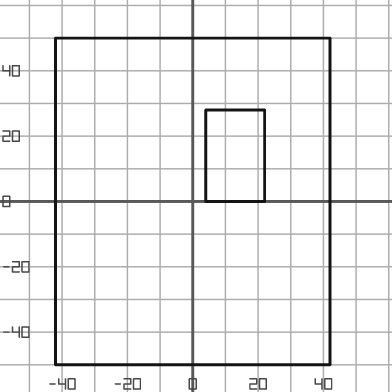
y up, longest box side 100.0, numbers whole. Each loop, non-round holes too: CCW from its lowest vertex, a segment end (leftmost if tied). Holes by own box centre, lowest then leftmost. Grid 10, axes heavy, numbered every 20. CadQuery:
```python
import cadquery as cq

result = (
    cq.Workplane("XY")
    .moveTo(-42.0, -50.0)
    .lineTo(42.0, -50.0)
    .lineTo(42.0, 50.0)
    .lineTo(-42.0, 50.0)
    .close()
    .moveTo(4.0, 0.0)
    .lineTo(22.0, 0.0)
    .lineTo(22.0, 28.0)
    .lineTo(4.0, 28.0)
    .close()
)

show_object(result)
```